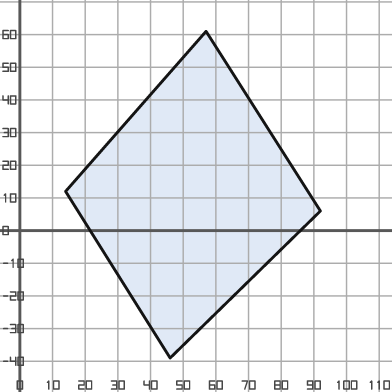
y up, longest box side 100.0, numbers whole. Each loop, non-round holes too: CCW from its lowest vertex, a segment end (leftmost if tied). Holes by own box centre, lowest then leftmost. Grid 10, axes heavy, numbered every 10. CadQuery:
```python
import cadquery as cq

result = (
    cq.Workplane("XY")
    .moveTo(46.0, -39.0)
    .lineTo(92.0, 6.0)
    .lineTo(57.0, 61.0)
    .lineTo(14.0, 12.0)
    .close()
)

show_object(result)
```